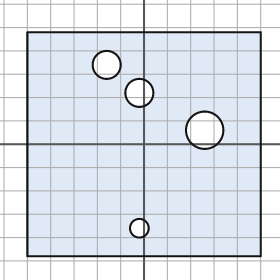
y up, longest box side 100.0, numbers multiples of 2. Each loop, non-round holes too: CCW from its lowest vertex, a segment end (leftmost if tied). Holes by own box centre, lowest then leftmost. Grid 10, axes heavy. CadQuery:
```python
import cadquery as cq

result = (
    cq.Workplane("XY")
    .moveTo(-50.0, -48.0)
    .lineTo(50.0, -48.0)
    .lineTo(50.0, 48.0)
    .lineTo(-50.0, 48.0)
    .close()
    .moveTo(-2.0, -36.0)
    .circle(4.0)
    .moveTo(26.0, 6.0)
    .circle(8.0)
    .moveTo(-2.0, 22.0)
    .circle(6.0)
    .moveTo(-16.0, 34.0)
    .circle(6.0)
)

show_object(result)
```